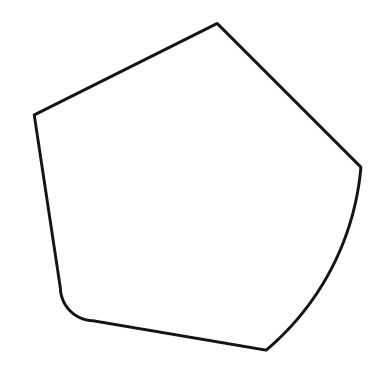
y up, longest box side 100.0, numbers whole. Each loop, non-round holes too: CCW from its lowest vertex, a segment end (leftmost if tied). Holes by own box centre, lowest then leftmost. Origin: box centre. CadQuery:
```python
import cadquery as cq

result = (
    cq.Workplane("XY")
    .moveTo(21.0, -50.0)
    .threePointArc((41.0, -25.0), (50.0, 6.0))
    .lineTo(6.0, 50.0)
    .lineTo(-50.0, 22.0)
    .lineTo(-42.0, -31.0)
    .threePointArc((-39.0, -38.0), (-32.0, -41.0))
    .close()
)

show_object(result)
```